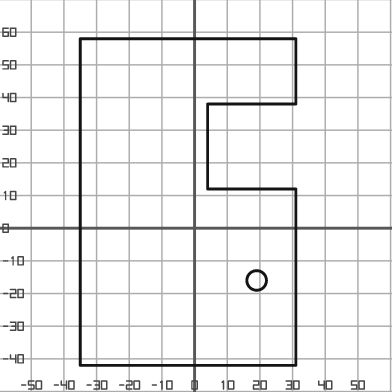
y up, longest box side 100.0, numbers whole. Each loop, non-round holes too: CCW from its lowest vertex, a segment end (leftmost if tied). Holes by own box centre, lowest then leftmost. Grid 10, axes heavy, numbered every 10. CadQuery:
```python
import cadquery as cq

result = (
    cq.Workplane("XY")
    .moveTo(-35.0, -42.0)
    .lineTo(31.0, -42.0)
    .lineTo(31.0, 12.0)
    .lineTo(4.0, 12.0)
    .lineTo(4.0, 38.0)
    .lineTo(31.0, 38.0)
    .lineTo(31.0, 58.0)
    .lineTo(-35.0, 58.0)
    .close()
    .moveTo(19.0, -16.0)
    .circle(3.0)
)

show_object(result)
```